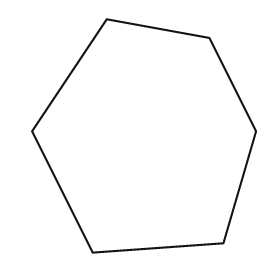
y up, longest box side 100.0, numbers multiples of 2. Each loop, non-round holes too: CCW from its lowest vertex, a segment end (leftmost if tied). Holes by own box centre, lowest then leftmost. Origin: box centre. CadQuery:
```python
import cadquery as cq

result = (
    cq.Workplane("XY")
    .moveTo(-22.0, -50.0)
    .lineTo(34.0, -46.0)
    .lineTo(48.0, 2.0)
    .lineTo(28.0, 42.0)
    .lineTo(-16.0, 50.0)
    .lineTo(-48.0, 2.0)
    .close()
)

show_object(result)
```